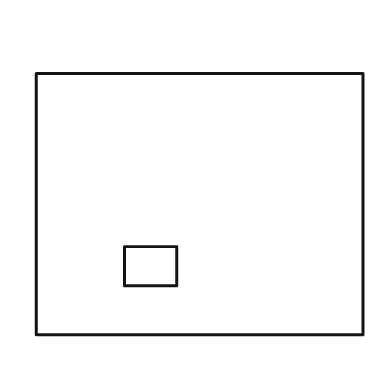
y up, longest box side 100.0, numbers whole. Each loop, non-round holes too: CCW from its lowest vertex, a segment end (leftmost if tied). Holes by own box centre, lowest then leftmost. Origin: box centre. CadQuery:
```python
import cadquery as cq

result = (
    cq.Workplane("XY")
    .moveTo(-50.0, -40.0)
    .lineTo(50.0, -40.0)
    .lineTo(50.0, 40.0)
    .lineTo(-50.0, 40.0)
    .close()
    .moveTo(-23.0, -25.0)
    .lineTo(-7.0, -25.0)
    .lineTo(-7.0, -13.0)
    .lineTo(-23.0, -13.0)
    .close()
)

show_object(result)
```